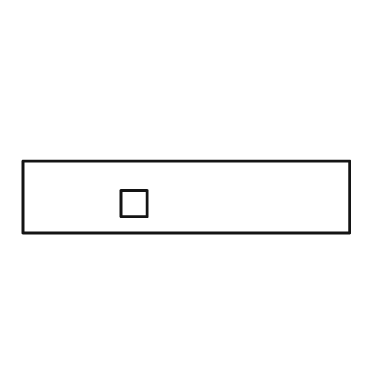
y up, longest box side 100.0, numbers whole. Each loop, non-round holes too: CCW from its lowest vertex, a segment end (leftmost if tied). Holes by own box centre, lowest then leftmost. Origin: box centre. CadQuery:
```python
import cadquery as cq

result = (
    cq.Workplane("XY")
    .moveTo(-50.0, -11.0)
    .lineTo(50.0, -11.0)
    .lineTo(50.0, 11.0)
    .lineTo(-50.0, 11.0)
    .close()
    .moveTo(-20.0, -6.0)
    .lineTo(-12.0, -6.0)
    .lineTo(-12.0, 2.0)
    .lineTo(-20.0, 2.0)
    .close()
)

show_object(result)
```